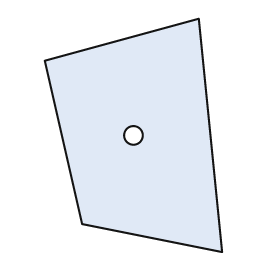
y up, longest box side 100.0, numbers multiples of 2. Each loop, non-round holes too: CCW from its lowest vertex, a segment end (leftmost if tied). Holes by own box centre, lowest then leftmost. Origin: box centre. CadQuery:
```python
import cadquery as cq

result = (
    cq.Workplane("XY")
    .moveTo(38.0, -50.0)
    .lineTo(28.0, 50.0)
    .lineTo(-38.0, 32.0)
    .lineTo(-22.0, -38.0)
    .close()
    .moveTo(0.0, 0.0)
    .circle(4.0)
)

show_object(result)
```